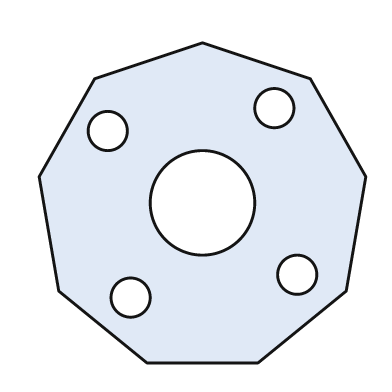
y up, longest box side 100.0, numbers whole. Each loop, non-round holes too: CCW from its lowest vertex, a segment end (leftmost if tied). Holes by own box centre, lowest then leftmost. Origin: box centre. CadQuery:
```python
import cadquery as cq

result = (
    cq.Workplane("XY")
    .moveTo(-17.0, -49.0)
    .lineTo(17.0, -49.0)
    .lineTo(44.0, -27.0)
    .lineTo(50.0, 8.0)
    .lineTo(33.0, 38.0)
    .lineTo(0.0, 49.0)
    .lineTo(-33.0, 38.0)
    .lineTo(-50.0, 8.0)
    .lineTo(-44.0, -27.0)
    .close()
    .moveTo(-22.0, -29.0)
    .circle(6.0)
    .moveTo(29.0, -22.0)
    .circle(6.0)
    .moveTo(0.0, 0.0)
    .circle(16.0)
    .moveTo(-29.0, 22.0)
    .circle(6.0)
    .moveTo(22.0, 29.0)
    .circle(6.0)
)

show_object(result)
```